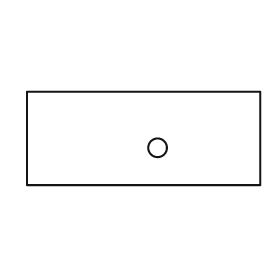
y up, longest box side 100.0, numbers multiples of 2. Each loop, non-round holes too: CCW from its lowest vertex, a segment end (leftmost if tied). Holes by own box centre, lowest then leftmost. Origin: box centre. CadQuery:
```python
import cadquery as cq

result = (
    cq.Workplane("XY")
    .moveTo(-50.0, -20.0)
    .lineTo(50.0, -20.0)
    .lineTo(50.0, 20.0)
    .lineTo(-50.0, 20.0)
    .close()
    .moveTo(6.0, -4.0)
    .circle(4.0)
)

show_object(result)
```